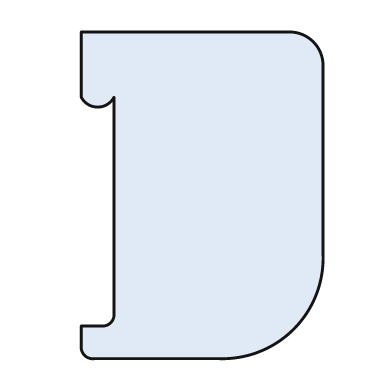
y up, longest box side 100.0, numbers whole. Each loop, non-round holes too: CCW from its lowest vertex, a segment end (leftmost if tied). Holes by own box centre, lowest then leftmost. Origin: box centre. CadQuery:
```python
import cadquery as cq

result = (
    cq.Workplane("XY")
    .moveTo(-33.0, -50.0)
    .lineTo(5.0, -50.0)
    .threePointArc((28.0, -41.0), (37.0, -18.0))
    .lineTo(37.0, 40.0)
    .threePointArc((34.0, 47.0), (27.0, 50.0))
    .lineTo(-37.0, 50.0)
    .lineTo(-37.0, 30.0)
    .threePointArc((-32.0, 27.0), (-27.0, 30.0))
    .lineTo(-27.0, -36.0)
    .threePointArc((-28.0, -39.0), (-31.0, -40.0))
    .lineTo(-37.0, -40.0)
    .lineTo(-37.0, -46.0)
    .threePointArc((-36.0, -49.0), (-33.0, -50.0))
    .close()
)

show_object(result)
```